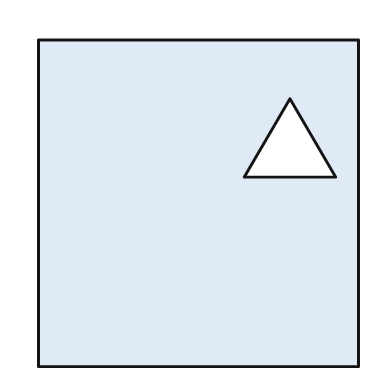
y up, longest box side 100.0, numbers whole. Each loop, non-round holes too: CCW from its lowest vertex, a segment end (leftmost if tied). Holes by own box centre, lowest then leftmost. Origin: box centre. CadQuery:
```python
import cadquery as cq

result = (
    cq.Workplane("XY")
    .moveTo(-49.0, -50.0)
    .lineTo(49.0, -50.0)
    .lineTo(49.0, 50.0)
    .lineTo(-49.0, 50.0)
    .close()
    .moveTo(14.0, 8.0)
    .lineTo(42.0, 8.0)
    .lineTo(28.0, 32.0)
    .close()
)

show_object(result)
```